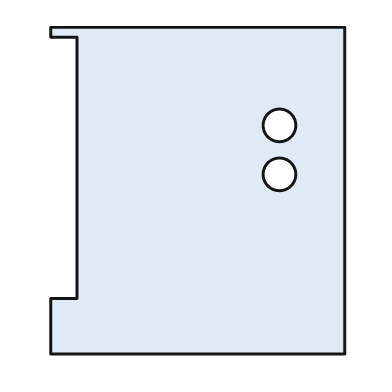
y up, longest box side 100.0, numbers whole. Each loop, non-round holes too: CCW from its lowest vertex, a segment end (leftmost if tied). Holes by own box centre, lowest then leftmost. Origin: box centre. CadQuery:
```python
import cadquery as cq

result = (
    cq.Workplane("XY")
    .moveTo(-45.0, -50.0)
    .lineTo(45.0, -50.0)
    .lineTo(45.0, 50.0)
    .lineTo(-45.0, 50.0)
    .lineTo(-45.0, 47.0)
    .lineTo(-37.0, 47.0)
    .lineTo(-37.0, -33.0)
    .lineTo(-45.0, -33.0)
    .close()
    .moveTo(25.0, 5.0)
    .circle(5.0)
    .moveTo(25.0, 20.0)
    .circle(5.0)
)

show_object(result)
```